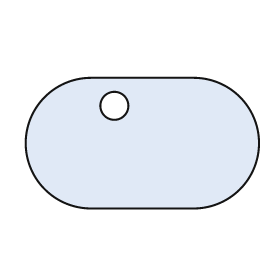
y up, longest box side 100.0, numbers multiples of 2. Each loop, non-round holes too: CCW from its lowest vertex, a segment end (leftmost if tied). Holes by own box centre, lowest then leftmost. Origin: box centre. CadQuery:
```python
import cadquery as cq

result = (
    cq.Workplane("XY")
    .moveTo(-22.0, -28.0)
    .lineTo(22.0, -28.0)
    .threePointArc((50.0, 0.0), (22.0, 28.0))
    .lineTo(-22.0, 28.0)
    .threePointArc((-50.0, 0.0), (-22.0, -28.0))
    .close()
    .moveTo(-12.0, 16.0)
    .circle(6.0)
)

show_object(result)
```